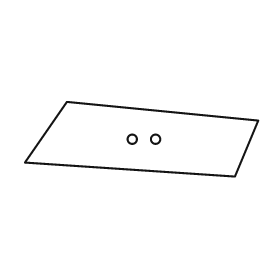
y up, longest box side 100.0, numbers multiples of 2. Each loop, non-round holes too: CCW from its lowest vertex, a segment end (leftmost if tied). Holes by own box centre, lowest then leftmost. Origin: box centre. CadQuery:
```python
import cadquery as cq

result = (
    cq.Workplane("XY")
    .moveTo(40.0, -16.0)
    .lineTo(50.0, 8.0)
    .lineTo(-32.0, 16.0)
    .lineTo(-50.0, -10.0)
    .close()
    .moveTo(-4.0, 0.0)
    .circle(2.0)
    .moveTo(6.0, 0.0)
    .circle(2.0)
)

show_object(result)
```